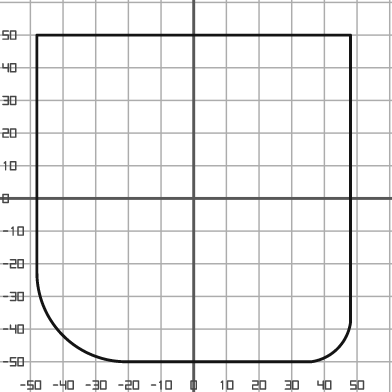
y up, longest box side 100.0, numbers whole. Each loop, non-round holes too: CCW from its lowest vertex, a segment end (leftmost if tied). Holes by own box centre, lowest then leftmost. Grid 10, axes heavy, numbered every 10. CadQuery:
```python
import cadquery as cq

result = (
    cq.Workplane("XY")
    .moveTo(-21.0, -50.0)
    .lineTo(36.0, -50.0)
    .threePointArc((44.0, -46.0), (48.0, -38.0))
    .lineTo(48.0, 50.0)
    .lineTo(-48.0, 50.0)
    .lineTo(-48.0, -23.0)
    .threePointArc((-40.0, -42.0), (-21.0, -50.0))
    .close()
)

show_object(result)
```